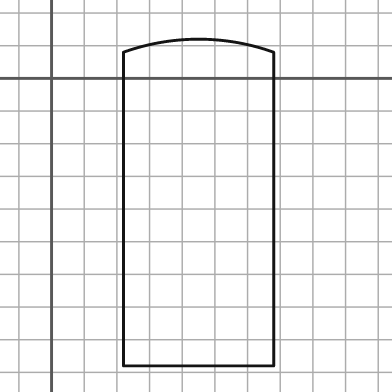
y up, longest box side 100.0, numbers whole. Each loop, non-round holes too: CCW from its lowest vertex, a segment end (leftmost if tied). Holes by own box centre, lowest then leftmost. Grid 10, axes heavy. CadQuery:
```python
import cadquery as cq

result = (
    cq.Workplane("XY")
    .moveTo(22.0, -88.0)
    .lineTo(68.0, -88.0)
    .lineTo(68.0, 8.0)
    .threePointArc((45.0, 12.0), (22.0, 8.0))
    .close()
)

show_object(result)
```